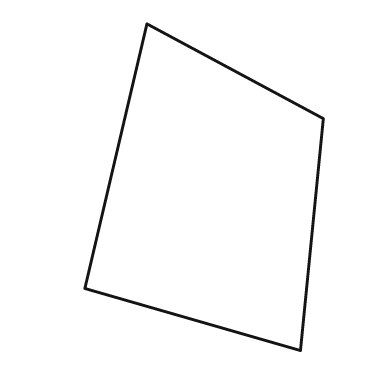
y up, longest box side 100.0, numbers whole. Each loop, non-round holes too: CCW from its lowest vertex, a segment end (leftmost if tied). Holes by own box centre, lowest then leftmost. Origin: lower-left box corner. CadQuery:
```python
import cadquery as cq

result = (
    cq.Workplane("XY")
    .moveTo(66.0, 0.0)
    .lineTo(73.0, 71.0)
    .lineTo(19.0, 100.0)
    .lineTo(0.0, 19.0)
    .close()
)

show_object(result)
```